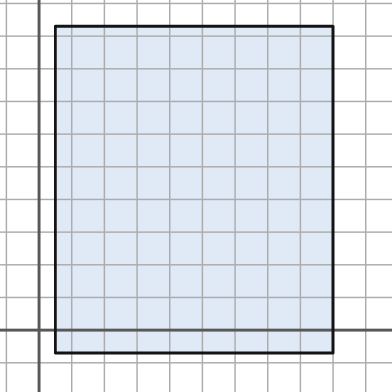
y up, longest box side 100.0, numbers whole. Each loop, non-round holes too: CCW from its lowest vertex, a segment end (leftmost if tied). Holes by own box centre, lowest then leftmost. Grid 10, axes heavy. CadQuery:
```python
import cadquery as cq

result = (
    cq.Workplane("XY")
    .moveTo(5.0, -7.0)
    .lineTo(90.0, -7.0)
    .lineTo(90.0, 93.0)
    .lineTo(5.0, 93.0)
    .close()
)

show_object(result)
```